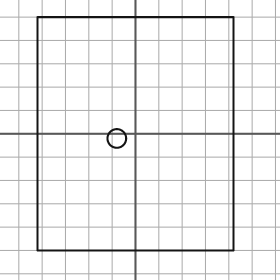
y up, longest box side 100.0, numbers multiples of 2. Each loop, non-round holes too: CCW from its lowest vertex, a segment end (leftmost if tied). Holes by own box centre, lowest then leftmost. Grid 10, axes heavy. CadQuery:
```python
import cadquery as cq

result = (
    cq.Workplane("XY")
    .moveTo(-42.0, -50.0)
    .lineTo(42.0, -50.0)
    .lineTo(42.0, 50.0)
    .lineTo(-42.0, 50.0)
    .close()
    .moveTo(-8.0, -2.0)
    .circle(4.0)
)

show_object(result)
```